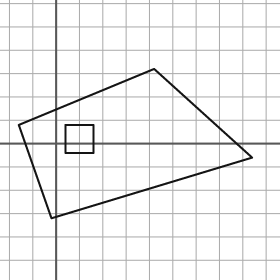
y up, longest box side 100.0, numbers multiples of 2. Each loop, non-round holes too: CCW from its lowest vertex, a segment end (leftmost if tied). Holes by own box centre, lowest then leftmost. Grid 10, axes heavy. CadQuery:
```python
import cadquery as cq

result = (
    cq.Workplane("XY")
    .moveTo(-2.0, -32.0)
    .lineTo(84.0, -6.0)
    .lineTo(42.0, 32.0)
    .lineTo(-16.0, 8.0)
    .close()
    .moveTo(4.0, -4.0)
    .lineTo(16.0, -4.0)
    .lineTo(16.0, 8.0)
    .lineTo(4.0, 8.0)
    .close()
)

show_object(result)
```